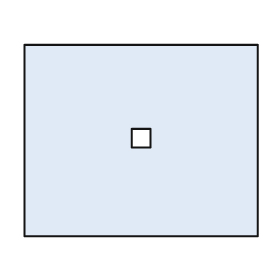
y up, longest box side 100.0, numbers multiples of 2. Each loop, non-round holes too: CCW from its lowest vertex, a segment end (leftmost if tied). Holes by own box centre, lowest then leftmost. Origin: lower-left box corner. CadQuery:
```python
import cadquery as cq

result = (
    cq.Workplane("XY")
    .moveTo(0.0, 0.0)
    .lineTo(100.0, 0.0)
    .lineTo(100.0, 82.0)
    .lineTo(0.0, 82.0)
    .close()
    .moveTo(46.0, 38.0)
    .lineTo(54.0, 38.0)
    .lineTo(54.0, 46.0)
    .lineTo(46.0, 46.0)
    .close()
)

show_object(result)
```